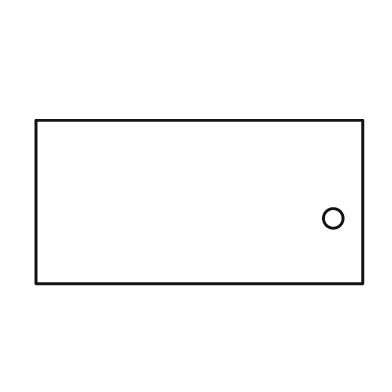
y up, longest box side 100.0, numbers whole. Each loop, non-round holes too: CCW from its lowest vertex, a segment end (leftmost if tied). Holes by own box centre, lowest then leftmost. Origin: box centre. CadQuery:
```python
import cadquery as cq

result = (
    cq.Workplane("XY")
    .moveTo(-50.0, -25.0)
    .lineTo(50.0, -25.0)
    .lineTo(50.0, 25.0)
    .lineTo(-50.0, 25.0)
    .close()
    .moveTo(41.0, -5.0)
    .circle(3.0)
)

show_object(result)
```